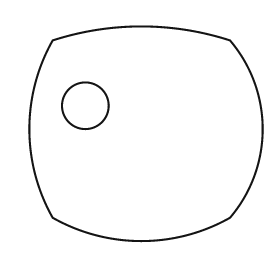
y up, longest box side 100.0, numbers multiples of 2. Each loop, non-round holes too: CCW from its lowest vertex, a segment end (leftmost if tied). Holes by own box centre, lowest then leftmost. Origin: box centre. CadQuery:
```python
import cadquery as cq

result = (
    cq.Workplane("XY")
    .moveTo(-40.0, -36.0)
    .threePointArc((-2.0, -46.0), (36.0, -36.0))
    .threePointArc((50.0, 2.0), (36.0, 40.0))
    .threePointArc((-2.0, 46.0), (-40.0, 40.0))
    .threePointArc((-50.0, 2.0), (-40.0, -36.0))
    .close()
    .moveTo(-26.0, 12.0)
    .circle(10.0)
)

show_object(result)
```